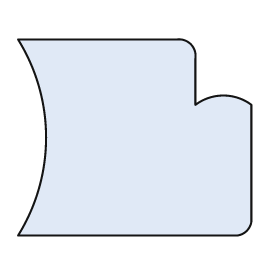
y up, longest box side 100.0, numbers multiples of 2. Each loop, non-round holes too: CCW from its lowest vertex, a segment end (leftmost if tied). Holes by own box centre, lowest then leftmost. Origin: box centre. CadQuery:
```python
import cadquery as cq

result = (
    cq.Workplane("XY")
    .moveTo(-50.0, -42.0)
    .lineTo(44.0, -42.0)
    .threePointArc((48.0, -40.0), (50.0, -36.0))
    .lineTo(50.0, 14.0)
    .threePointArc((38.0, 18.0), (26.0, 14.0))
    .lineTo(26.0, 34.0)
    .threePointArc((24.0, 40.0), (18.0, 42.0))
    .lineTo(-50.0, 42.0)
    .threePointArc((-38.0, 0.0), (-50.0, -42.0))
    .close()
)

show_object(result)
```